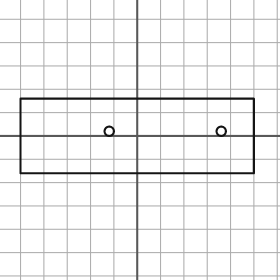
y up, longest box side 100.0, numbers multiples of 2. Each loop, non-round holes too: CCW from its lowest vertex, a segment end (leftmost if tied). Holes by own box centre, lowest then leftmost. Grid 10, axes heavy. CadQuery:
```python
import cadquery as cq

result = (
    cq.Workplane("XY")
    .moveTo(-50.0, -16.0)
    .lineTo(50.0, -16.0)
    .lineTo(50.0, 16.0)
    .lineTo(-50.0, 16.0)
    .close()
    .moveTo(-12.0, 2.0)
    .circle(2.0)
    .moveTo(36.0, 2.0)
    .circle(2.0)
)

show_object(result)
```